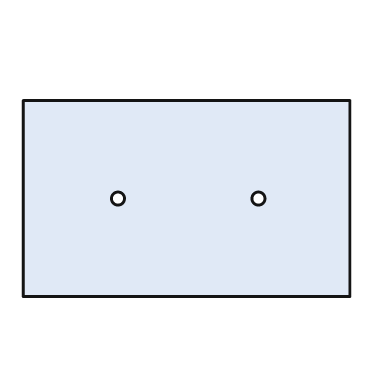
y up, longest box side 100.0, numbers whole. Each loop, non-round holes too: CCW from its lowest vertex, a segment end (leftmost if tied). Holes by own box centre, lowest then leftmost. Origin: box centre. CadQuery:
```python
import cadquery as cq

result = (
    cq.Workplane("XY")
    .moveTo(-50.0, -30.0)
    .lineTo(50.0, -30.0)
    .lineTo(50.0, 30.0)
    .lineTo(-50.0, 30.0)
    .close()
    .moveTo(-21.0, 0.0)
    .circle(2.0)
    .moveTo(22.0, 0.0)
    .circle(2.0)
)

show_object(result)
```